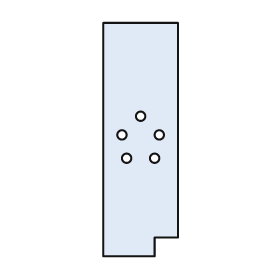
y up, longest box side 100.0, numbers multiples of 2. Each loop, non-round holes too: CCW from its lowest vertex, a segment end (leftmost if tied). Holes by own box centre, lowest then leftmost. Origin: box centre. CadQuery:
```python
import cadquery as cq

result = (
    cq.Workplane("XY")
    .moveTo(-16.0, -50.0)
    .lineTo(6.0, -50.0)
    .lineTo(6.0, -42.0)
    .lineTo(16.0, -42.0)
    .lineTo(16.0, 50.0)
    .lineTo(-16.0, 50.0)
    .close()
    .moveTo(-6.0, -8.0)
    .circle(2.0)
    .moveTo(6.0, -8.0)
    .circle(2.0)
    .moveTo(-8.0, 2.0)
    .circle(2.0)
    .moveTo(8.0, 2.0)
    .circle(2.0)
    .moveTo(0.0, 10.0)
    .circle(2.0)
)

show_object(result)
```